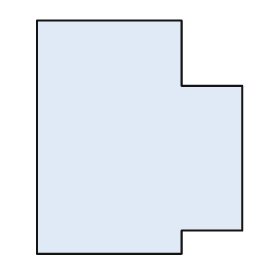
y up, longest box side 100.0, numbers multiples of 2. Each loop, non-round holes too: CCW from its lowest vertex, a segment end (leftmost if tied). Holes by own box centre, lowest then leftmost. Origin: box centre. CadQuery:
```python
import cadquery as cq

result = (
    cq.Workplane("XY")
    .moveTo(-44.0, -50.0)
    .lineTo(18.0, -50.0)
    .lineTo(18.0, -40.0)
    .lineTo(44.0, -40.0)
    .lineTo(44.0, 22.0)
    .lineTo(18.0, 22.0)
    .lineTo(18.0, 50.0)
    .lineTo(-44.0, 50.0)
    .close()
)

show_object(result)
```